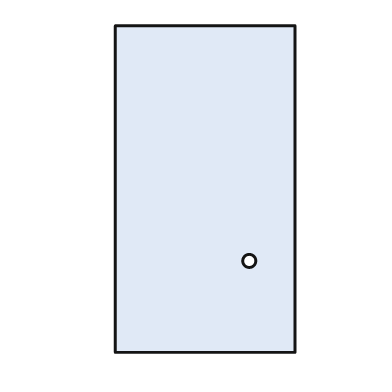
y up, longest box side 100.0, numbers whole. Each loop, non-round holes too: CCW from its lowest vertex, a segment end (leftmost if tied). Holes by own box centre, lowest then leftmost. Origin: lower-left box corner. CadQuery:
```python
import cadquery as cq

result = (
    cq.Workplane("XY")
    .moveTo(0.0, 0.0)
    .lineTo(55.0, 0.0)
    .lineTo(55.0, 100.0)
    .lineTo(0.0, 100.0)
    .close()
    .moveTo(41.0, 28.0)
    .circle(2.0)
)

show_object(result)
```